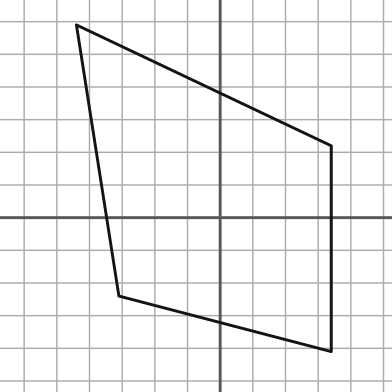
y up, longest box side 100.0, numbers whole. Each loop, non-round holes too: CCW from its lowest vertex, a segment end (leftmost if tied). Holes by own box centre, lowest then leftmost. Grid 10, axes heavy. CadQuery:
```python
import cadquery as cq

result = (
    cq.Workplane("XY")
    .moveTo(34.0, -41.0)
    .lineTo(34.0, 22.0)
    .lineTo(-44.0, 59.0)
    .lineTo(-31.0, -24.0)
    .close()
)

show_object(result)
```